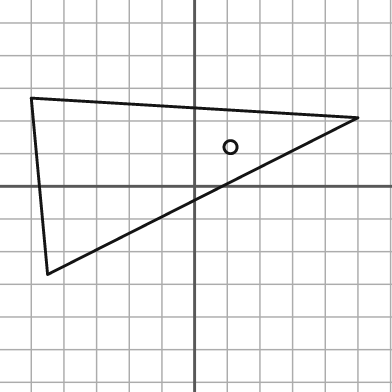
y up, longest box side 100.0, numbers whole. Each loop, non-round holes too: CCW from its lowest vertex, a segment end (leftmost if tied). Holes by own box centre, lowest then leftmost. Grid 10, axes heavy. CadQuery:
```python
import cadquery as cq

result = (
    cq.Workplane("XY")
    .moveTo(-45.0, -27.0)
    .lineTo(50.0, 21.0)
    .lineTo(-50.0, 27.0)
    .close()
    .moveTo(11.0, 12.0)
    .circle(2.0)
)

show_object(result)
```